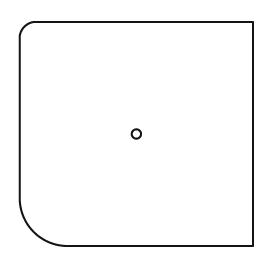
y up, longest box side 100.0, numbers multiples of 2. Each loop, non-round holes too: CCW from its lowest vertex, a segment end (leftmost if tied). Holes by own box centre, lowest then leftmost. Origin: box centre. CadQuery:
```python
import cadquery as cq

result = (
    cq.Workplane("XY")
    .moveTo(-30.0, -48.0)
    .lineTo(50.0, -48.0)
    .lineTo(50.0, 48.0)
    .lineTo(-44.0, 48.0)
    .threePointArc((-48.0, 46.0), (-50.0, 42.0))
    .lineTo(-50.0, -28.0)
    .threePointArc((-44.0, -42.0), (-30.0, -48.0))
    .close()
    .moveTo(0.0, 0.0)
    .circle(2.0)
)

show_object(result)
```